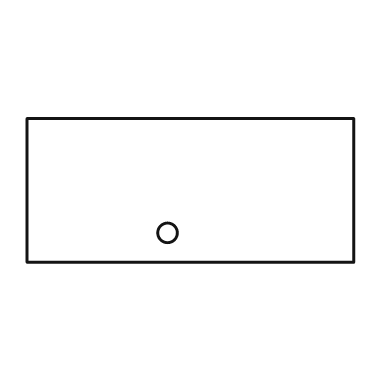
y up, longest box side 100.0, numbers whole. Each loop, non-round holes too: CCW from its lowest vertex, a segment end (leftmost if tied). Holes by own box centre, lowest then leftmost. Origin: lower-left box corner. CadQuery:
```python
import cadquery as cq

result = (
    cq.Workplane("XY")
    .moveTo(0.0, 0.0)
    .lineTo(100.0, 0.0)
    .lineTo(100.0, 44.0)
    .lineTo(0.0, 44.0)
    .close()
    .moveTo(43.0, 9.0)
    .circle(3.0)
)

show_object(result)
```